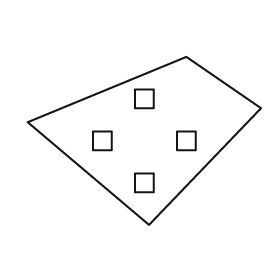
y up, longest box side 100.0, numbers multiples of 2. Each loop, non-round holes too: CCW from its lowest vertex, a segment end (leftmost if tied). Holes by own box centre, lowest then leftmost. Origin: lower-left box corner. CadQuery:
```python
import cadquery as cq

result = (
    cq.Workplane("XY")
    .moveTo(52.0, 0.0)
    .lineTo(100.0, 50.0)
    .lineTo(68.0, 72.0)
    .lineTo(0.0, 44.0)
    .close()
    .moveTo(46.0, 14.0)
    .lineTo(54.0, 14.0)
    .lineTo(54.0, 22.0)
    .lineTo(46.0, 22.0)
    .close()
    .moveTo(28.0, 32.0)
    .lineTo(36.0, 32.0)
    .lineTo(36.0, 40.0)
    .lineTo(28.0, 40.0)
    .close()
    .moveTo(64.0, 32.0)
    .lineTo(72.0, 32.0)
    .lineTo(72.0, 40.0)
    .lineTo(64.0, 40.0)
    .close()
    .moveTo(46.0, 50.0)
    .lineTo(54.0, 50.0)
    .lineTo(54.0, 58.0)
    .lineTo(46.0, 58.0)
    .close()
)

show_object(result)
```